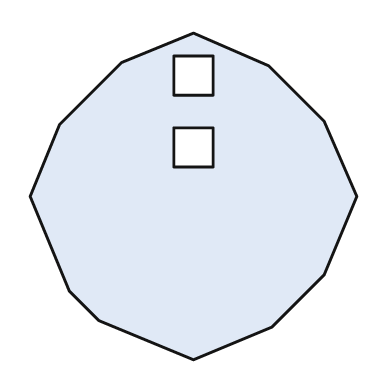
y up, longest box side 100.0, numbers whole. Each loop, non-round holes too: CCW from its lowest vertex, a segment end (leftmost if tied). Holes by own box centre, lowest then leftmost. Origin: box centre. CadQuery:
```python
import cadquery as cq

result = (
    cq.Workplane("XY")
    .moveTo(0.0, -50.0)
    .lineTo(24.0, -40.0)
    .lineTo(40.0, -24.0)
    .lineTo(50.0, 0.0)
    .lineTo(40.0, 23.0)
    .lineTo(23.0, 40.0)
    .lineTo(0.0, 50.0)
    .lineTo(-22.0, 41.0)
    .lineTo(-41.0, 22.0)
    .lineTo(-50.0, 0.0)
    .lineTo(-38.0, -29.0)
    .lineTo(-29.0, -38.0)
    .close()
    .moveTo(-6.0, 9.0)
    .lineTo(6.0, 9.0)
    .lineTo(6.0, 21.0)
    .lineTo(-6.0, 21.0)
    .close()
    .moveTo(-6.0, 31.0)
    .lineTo(6.0, 31.0)
    .lineTo(6.0, 43.0)
    .lineTo(-6.0, 43.0)
    .close()
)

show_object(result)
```